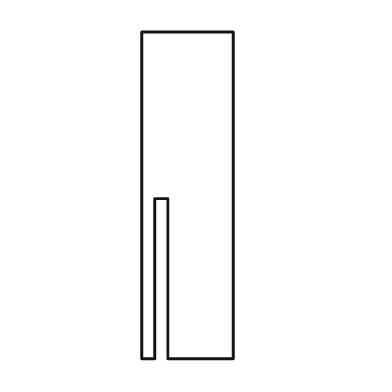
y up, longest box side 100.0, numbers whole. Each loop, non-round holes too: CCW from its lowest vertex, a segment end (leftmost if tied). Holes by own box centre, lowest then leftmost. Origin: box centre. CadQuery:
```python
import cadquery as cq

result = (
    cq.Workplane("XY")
    .moveTo(-14.0, -50.0)
    .lineTo(-10.0, -50.0)
    .lineTo(-10.0, -1.0)
    .lineTo(-6.0, -1.0)
    .lineTo(-6.0, -50.0)
    .lineTo(14.0, -50.0)
    .lineTo(14.0, 50.0)
    .lineTo(-14.0, 50.0)
    .close()
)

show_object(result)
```